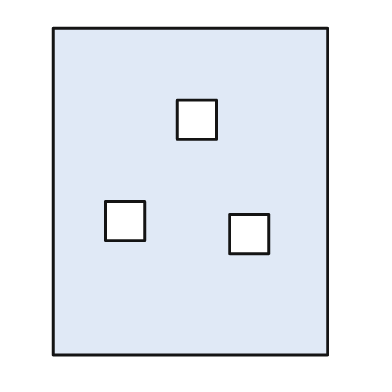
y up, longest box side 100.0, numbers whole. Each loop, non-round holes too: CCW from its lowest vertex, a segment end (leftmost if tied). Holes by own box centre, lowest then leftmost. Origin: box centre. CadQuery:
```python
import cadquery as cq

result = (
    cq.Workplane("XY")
    .moveTo(-42.0, -50.0)
    .lineTo(42.0, -50.0)
    .lineTo(42.0, 50.0)
    .lineTo(-42.0, 50.0)
    .close()
    .moveTo(12.0, -19.0)
    .lineTo(24.0, -19.0)
    .lineTo(24.0, -7.0)
    .lineTo(12.0, -7.0)
    .close()
    .moveTo(-26.0, -15.0)
    .lineTo(-14.0, -15.0)
    .lineTo(-14.0, -3.0)
    .lineTo(-26.0, -3.0)
    .close()
    .moveTo(-4.0, 16.0)
    .lineTo(8.0, 16.0)
    .lineTo(8.0, 28.0)
    .lineTo(-4.0, 28.0)
    .close()
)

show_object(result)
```